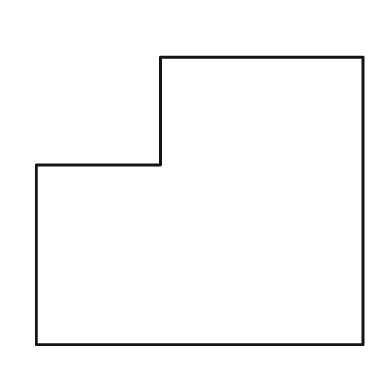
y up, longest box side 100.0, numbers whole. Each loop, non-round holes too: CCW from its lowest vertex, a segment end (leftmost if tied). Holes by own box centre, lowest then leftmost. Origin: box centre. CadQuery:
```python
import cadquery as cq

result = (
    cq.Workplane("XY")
    .moveTo(-50.0, -44.0)
    .lineTo(50.0, -44.0)
    .lineTo(50.0, 44.0)
    .lineTo(-12.0, 44.0)
    .lineTo(-12.0, 11.0)
    .lineTo(-50.0, 11.0)
    .close()
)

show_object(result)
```